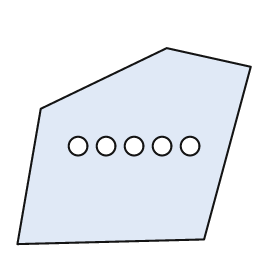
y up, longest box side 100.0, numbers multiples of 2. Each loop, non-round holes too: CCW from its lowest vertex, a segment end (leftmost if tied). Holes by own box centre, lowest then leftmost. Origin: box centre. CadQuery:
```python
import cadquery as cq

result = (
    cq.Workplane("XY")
    .moveTo(-50.0, -42.0)
    .lineTo(30.0, -40.0)
    .lineTo(50.0, 34.0)
    .lineTo(14.0, 42.0)
    .lineTo(-40.0, 16.0)
    .close()
    .moveTo(-24.0, 0.0)
    .circle(4.0)
    .moveTo(-12.0, 0.0)
    .circle(4.0)
    .moveTo(0.0, 0.0)
    .circle(4.0)
    .moveTo(12.0, 0.0)
    .circle(4.0)
    .moveTo(24.0, 0.0)
    .circle(4.0)
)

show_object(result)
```